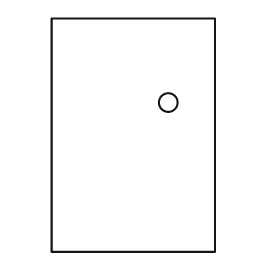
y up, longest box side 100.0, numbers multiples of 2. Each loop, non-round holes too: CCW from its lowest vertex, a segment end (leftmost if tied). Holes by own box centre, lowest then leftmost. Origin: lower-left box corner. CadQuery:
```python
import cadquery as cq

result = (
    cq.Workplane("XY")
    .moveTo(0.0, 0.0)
    .lineTo(70.0, 0.0)
    .lineTo(70.0, 100.0)
    .lineTo(0.0, 100.0)
    .close()
    .moveTo(50.0, 64.0)
    .circle(4.0)
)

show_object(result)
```